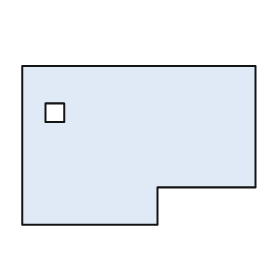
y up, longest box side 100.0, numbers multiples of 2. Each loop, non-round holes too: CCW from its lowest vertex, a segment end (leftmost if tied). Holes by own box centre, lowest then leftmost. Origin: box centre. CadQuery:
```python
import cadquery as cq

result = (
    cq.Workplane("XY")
    .moveTo(-50.0, -34.0)
    .lineTo(8.0, -34.0)
    .lineTo(8.0, -18.0)
    .lineTo(50.0, -18.0)
    .lineTo(50.0, 34.0)
    .lineTo(-50.0, 34.0)
    .close()
    .moveTo(-40.0, 10.0)
    .lineTo(-32.0, 10.0)
    .lineTo(-32.0, 18.0)
    .lineTo(-40.0, 18.0)
    .close()
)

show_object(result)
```